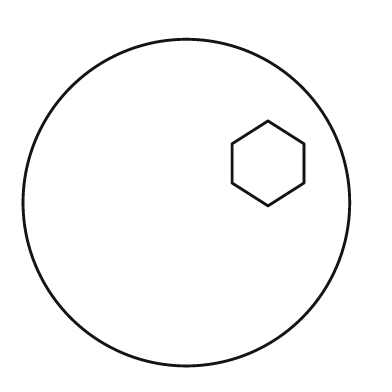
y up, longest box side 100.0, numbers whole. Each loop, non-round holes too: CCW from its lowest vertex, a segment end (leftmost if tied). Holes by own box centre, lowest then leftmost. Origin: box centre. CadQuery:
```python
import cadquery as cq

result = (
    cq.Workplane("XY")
    .moveTo(0.0, 0.0)
    .circle(50.0)
    .moveTo(25.0, -1.0)
    .lineTo(36.0, 6.0)
    .lineTo(36.0, 18.0)
    .lineTo(25.0, 25.0)
    .lineTo(14.0, 18.0)
    .lineTo(14.0, 6.0)
    .close()
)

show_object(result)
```